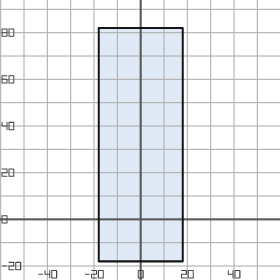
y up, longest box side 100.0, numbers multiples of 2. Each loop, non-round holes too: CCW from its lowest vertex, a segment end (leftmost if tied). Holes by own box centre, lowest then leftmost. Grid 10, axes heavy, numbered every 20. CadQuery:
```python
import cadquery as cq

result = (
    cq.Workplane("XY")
    .moveTo(-18.0, -18.0)
    .lineTo(18.0, -18.0)
    .lineTo(18.0, 82.0)
    .lineTo(-18.0, 82.0)
    .close()
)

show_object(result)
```